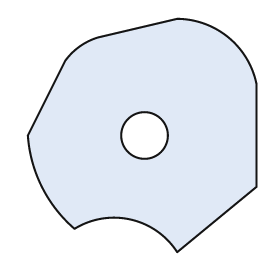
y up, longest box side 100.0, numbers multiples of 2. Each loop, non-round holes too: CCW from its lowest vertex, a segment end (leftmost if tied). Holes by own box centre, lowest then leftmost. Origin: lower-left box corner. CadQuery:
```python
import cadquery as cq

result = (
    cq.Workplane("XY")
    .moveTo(64.0, 0.0)
    .lineTo(98.0, 28.0)
    .lineTo(98.0, 72.0)
    .threePointArc((86.0, 92.0), (64.0, 100.0))
    .lineTo(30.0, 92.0)
    .threePointArc((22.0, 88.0), (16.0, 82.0))
    .lineTo(0.0, 50.0)
    .threePointArc((6.0, 28.0), (20.0, 10.0))
    .threePointArc((44.0, 14.0), (64.0, 0.0))
    .close()
    .moveTo(50.0, 50.0)
    .circle(10.0)
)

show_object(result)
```